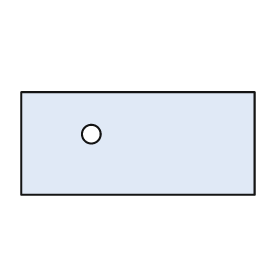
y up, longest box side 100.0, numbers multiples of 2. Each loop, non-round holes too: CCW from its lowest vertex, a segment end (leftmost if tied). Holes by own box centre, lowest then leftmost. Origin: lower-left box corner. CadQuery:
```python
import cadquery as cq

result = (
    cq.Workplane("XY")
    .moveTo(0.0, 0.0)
    .lineTo(100.0, 0.0)
    .lineTo(100.0, 44.0)
    .lineTo(0.0, 44.0)
    .close()
    .moveTo(30.0, 26.0)
    .circle(4.0)
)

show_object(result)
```